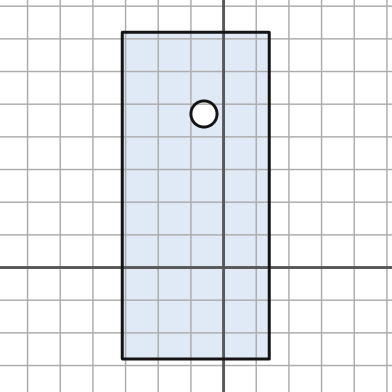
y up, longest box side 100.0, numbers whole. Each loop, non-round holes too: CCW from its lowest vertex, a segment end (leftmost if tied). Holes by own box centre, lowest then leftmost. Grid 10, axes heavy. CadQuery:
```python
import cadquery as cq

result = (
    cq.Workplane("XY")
    .moveTo(-31.0, -28.0)
    .lineTo(14.0, -28.0)
    .lineTo(14.0, 72.0)
    .lineTo(-31.0, 72.0)
    .close()
    .moveTo(-6.0, 47.0)
    .circle(4.0)
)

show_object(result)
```